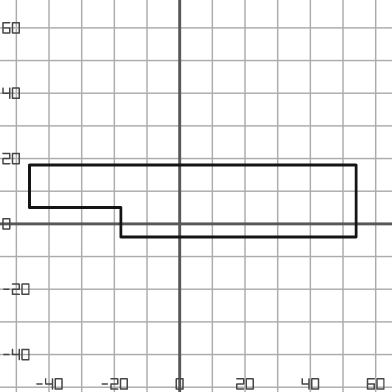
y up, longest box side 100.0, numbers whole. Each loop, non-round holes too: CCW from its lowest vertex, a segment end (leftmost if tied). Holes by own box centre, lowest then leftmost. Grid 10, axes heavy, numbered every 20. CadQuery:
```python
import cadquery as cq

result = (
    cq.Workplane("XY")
    .moveTo(-18.0, -4.0)
    .lineTo(54.0, -4.0)
    .lineTo(54.0, 18.0)
    .lineTo(-46.0, 18.0)
    .lineTo(-46.0, 5.0)
    .lineTo(-18.0, 5.0)
    .close()
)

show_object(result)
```